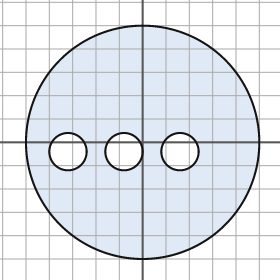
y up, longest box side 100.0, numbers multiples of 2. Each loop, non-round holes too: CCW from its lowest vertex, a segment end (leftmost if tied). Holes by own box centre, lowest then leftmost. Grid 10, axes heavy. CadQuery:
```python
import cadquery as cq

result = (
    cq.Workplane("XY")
    .moveTo(0.0, 0.0)
    .circle(50.0)
    .moveTo(-32.0, -4.0)
    .circle(8.0)
    .moveTo(-8.0, -4.0)
    .circle(8.0)
    .moveTo(16.0, -4.0)
    .circle(8.0)
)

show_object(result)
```